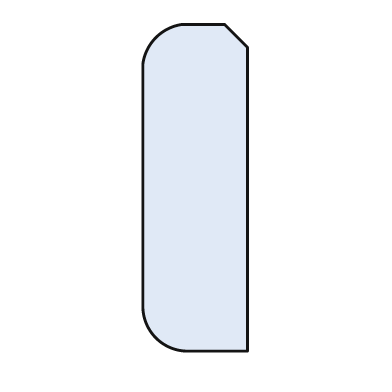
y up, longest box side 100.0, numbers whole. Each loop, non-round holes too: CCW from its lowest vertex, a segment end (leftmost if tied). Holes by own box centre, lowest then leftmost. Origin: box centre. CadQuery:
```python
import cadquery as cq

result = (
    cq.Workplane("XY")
    .moveTo(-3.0, -50.0)
    .lineTo(16.0, -50.0)
    .lineTo(16.0, 43.0)
    .lineTo(9.0, 50.0)
    .lineTo(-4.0, 50.0)
    .threePointArc((-12.0, 46.0), (-16.0, 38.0))
    .lineTo(-16.0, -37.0)
    .threePointArc((-12.0, -46.0), (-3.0, -50.0))
    .close()
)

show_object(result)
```